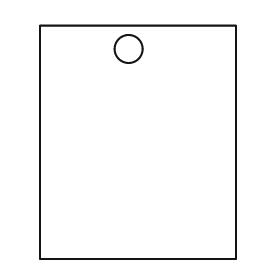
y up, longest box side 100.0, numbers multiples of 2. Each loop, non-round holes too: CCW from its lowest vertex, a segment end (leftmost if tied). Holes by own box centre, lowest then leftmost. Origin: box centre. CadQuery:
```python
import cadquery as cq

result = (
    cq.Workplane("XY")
    .moveTo(-42.0, -50.0)
    .lineTo(42.0, -50.0)
    .lineTo(42.0, 50.0)
    .lineTo(-42.0, 50.0)
    .close()
    .moveTo(-4.0, 40.0)
    .circle(6.0)
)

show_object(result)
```